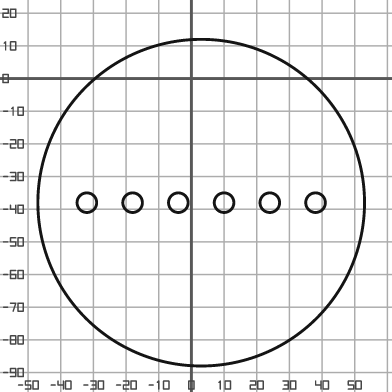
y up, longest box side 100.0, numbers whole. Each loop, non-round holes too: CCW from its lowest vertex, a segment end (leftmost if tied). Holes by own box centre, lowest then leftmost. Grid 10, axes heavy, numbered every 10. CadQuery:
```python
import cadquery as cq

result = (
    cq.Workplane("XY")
    .moveTo(3.0, -38.0)
    .circle(50.0)
    .moveTo(-32.0, -38.0)
    .circle(3.0)
    .moveTo(-18.0, -38.0)
    .circle(3.0)
    .moveTo(-4.0, -38.0)
    .circle(3.0)
    .moveTo(10.0, -38.0)
    .circle(3.0)
    .moveTo(24.0, -38.0)
    .circle(3.0)
    .moveTo(38.0, -38.0)
    .circle(3.0)
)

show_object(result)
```